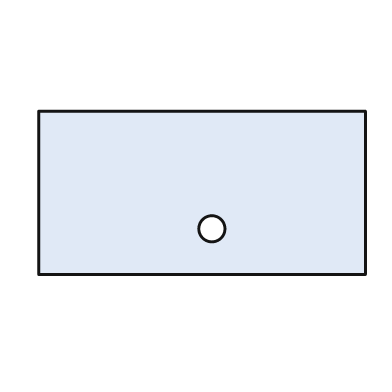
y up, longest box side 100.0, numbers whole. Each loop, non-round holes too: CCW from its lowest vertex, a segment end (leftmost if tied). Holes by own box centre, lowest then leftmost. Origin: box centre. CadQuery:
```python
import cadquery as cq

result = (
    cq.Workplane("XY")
    .moveTo(-50.0, -25.0)
    .lineTo(50.0, -25.0)
    .lineTo(50.0, 25.0)
    .lineTo(-50.0, 25.0)
    .close()
    .moveTo(3.0, -11.0)
    .circle(4.0)
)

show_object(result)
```